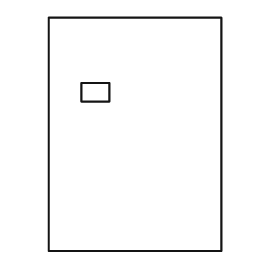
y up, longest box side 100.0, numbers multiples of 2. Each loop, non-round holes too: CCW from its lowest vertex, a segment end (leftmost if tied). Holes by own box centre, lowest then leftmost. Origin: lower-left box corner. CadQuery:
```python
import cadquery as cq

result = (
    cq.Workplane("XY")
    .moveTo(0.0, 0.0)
    .lineTo(74.0, 0.0)
    .lineTo(74.0, 100.0)
    .lineTo(0.0, 100.0)
    .close()
    .moveTo(14.0, 64.0)
    .lineTo(26.0, 64.0)
    .lineTo(26.0, 72.0)
    .lineTo(14.0, 72.0)
    .close()
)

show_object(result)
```